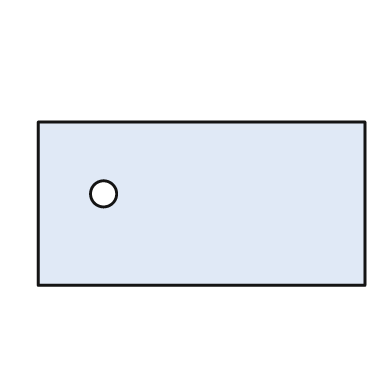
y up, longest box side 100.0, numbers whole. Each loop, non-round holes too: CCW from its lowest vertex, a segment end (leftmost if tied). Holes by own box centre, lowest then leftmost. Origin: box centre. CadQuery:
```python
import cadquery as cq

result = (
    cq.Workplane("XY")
    .moveTo(-50.0, -25.0)
    .lineTo(50.0, -25.0)
    .lineTo(50.0, 25.0)
    .lineTo(-50.0, 25.0)
    .close()
    .moveTo(-30.0, 3.0)
    .circle(4.0)
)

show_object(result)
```